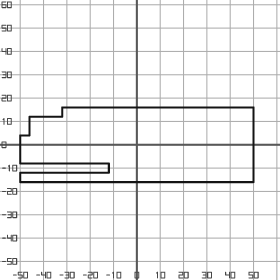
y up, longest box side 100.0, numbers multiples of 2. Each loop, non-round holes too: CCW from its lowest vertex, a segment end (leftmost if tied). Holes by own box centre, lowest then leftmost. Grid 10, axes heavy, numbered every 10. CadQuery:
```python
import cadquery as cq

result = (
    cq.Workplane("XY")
    .moveTo(-50.0, -16.0)
    .lineTo(50.0, -16.0)
    .lineTo(50.0, 16.0)
    .lineTo(-32.0, 16.0)
    .lineTo(-32.0, 12.0)
    .lineTo(-46.0, 12.0)
    .lineTo(-46.0, 4.0)
    .lineTo(-50.0, 4.0)
    .lineTo(-50.0, -8.0)
    .lineTo(-12.0, -8.0)
    .lineTo(-12.0, -12.0)
    .lineTo(-50.0, -12.0)
    .close()
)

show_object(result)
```